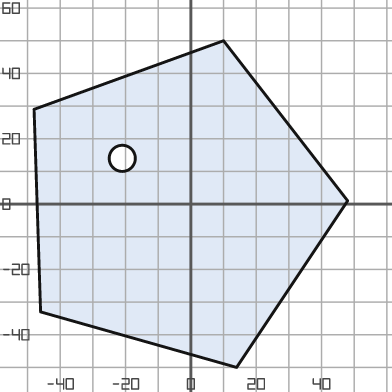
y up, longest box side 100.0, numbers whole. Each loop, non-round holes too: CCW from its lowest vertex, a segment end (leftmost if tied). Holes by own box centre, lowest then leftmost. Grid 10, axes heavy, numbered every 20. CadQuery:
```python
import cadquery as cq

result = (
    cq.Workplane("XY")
    .moveTo(14.0, -50.0)
    .lineTo(48.0, 1.0)
    .lineTo(10.0, 50.0)
    .lineTo(-48.0, 29.0)
    .lineTo(-46.0, -33.0)
    .close()
    .moveTo(-21.0, 14.0)
    .circle(4.0)
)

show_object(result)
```